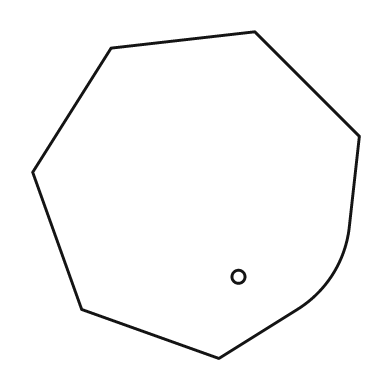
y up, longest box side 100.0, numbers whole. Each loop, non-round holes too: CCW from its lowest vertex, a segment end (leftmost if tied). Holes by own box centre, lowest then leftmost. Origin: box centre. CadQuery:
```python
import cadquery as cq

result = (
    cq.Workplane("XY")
    .moveTo(7.0, -50.0)
    .lineTo(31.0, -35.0)
    .threePointArc((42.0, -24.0), (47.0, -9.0))
    .lineTo(50.0, 18.0)
    .lineTo(18.0, 50.0)
    .lineTo(-26.0, 45.0)
    .lineTo(-50.0, 7.0)
    .lineTo(-35.0, -35.0)
    .close()
    .moveTo(13.0, -25.0)
    .circle(2.0)
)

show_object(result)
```